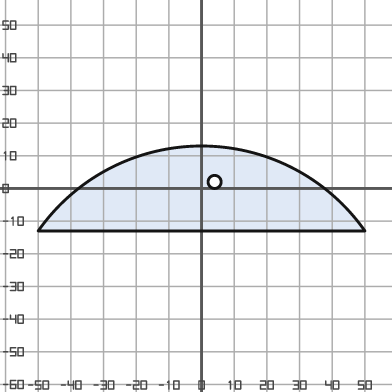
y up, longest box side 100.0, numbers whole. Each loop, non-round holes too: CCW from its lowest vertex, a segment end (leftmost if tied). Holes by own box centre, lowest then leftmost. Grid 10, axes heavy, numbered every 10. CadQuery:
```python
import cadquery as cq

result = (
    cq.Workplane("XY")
    .moveTo(-50.0, -13.0)
    .lineTo(50.0, -13.0)
    .threePointArc((0.0, 13.0), (-50.0, -13.0))
    .close()
    .moveTo(4.0, 2.0)
    .circle(2.0)
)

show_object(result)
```